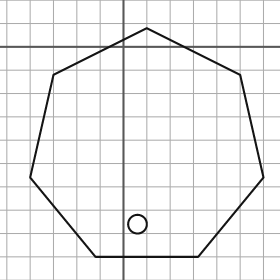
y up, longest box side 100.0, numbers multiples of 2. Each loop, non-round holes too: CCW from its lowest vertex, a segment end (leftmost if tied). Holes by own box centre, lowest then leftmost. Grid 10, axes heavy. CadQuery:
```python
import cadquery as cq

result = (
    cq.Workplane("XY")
    .moveTo(-12.0, -90.0)
    .lineTo(32.0, -90.0)
    .lineTo(60.0, -56.0)
    .lineTo(50.0, -12.0)
    .lineTo(10.0, 8.0)
    .lineTo(-30.0, -12.0)
    .lineTo(-40.0, -56.0)
    .close()
    .moveTo(6.0, -76.0)
    .circle(4.0)
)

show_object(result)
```